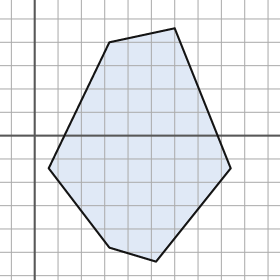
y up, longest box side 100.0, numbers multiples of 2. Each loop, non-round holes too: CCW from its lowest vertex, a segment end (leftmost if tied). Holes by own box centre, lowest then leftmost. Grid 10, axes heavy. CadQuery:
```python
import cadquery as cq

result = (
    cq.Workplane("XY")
    .moveTo(52.0, -54.0)
    .lineTo(84.0, -14.0)
    .lineTo(60.0, 46.0)
    .lineTo(32.0, 40.0)
    .lineTo(6.0, -14.0)
    .lineTo(32.0, -48.0)
    .close()
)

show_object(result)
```